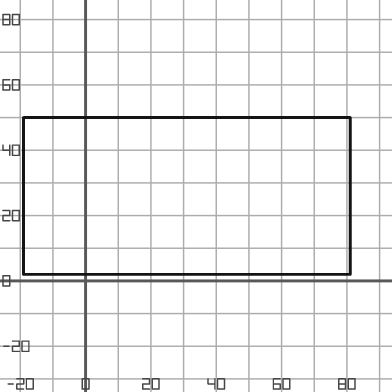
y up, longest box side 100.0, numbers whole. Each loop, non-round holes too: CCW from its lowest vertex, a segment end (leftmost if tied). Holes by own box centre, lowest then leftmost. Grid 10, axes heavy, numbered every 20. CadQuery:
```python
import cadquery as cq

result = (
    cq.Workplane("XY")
    .moveTo(-19.0, 2.0)
    .lineTo(81.0, 2.0)
    .lineTo(81.0, 50.0)
    .lineTo(-19.0, 50.0)
    .close()
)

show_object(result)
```